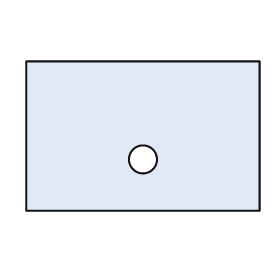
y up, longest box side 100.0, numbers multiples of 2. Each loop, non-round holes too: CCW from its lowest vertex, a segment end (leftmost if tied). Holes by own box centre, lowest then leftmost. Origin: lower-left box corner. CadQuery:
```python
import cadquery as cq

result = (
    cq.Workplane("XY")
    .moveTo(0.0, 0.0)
    .lineTo(100.0, 0.0)
    .lineTo(100.0, 64.0)
    .lineTo(0.0, 64.0)
    .close()
    .moveTo(50.0, 22.0)
    .circle(6.0)
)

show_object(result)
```